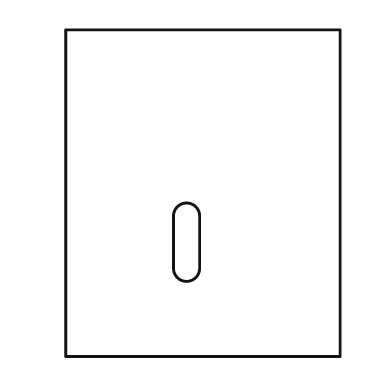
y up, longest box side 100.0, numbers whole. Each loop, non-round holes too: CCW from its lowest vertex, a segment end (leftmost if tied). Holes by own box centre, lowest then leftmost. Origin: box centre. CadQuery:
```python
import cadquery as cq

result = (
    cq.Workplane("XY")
    .moveTo(-42.0, -50.0)
    .lineTo(42.0, -50.0)
    .lineTo(42.0, 50.0)
    .lineTo(-42.0, 50.0)
    .close()
    .moveTo(-9.0, -23.0)
    .threePointArc((-5.0, -27.0), (-1.0, -23.0))
    .lineTo(-1.0, -7.0)
    .threePointArc((-5.0, -3.0), (-9.0, -7.0))
    .close()
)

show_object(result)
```